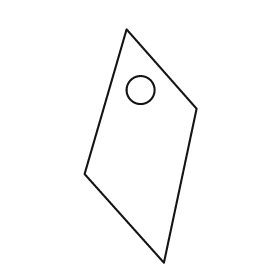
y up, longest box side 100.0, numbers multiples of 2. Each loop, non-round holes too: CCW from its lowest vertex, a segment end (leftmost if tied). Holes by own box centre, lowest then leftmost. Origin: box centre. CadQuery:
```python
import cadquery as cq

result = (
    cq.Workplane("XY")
    .moveTo(10.0, -50.0)
    .lineTo(24.0, 16.0)
    .lineTo(-6.0, 50.0)
    .lineTo(-24.0, -12.0)
    .close()
    .moveTo(0.0, 24.0)
    .circle(6.0)
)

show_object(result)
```